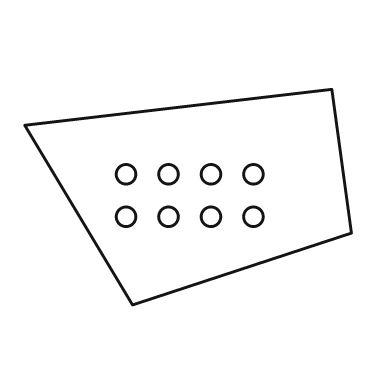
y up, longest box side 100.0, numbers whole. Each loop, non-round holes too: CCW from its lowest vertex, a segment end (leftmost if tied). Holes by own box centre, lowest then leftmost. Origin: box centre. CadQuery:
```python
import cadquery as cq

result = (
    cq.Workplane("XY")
    .moveTo(-17.0, -33.0)
    .lineTo(50.0, -11.0)
    .lineTo(44.0, 33.0)
    .lineTo(-50.0, 22.0)
    .close()
    .moveTo(-19.0, -6.0)
    .circle(3.0)
    .moveTo(-6.0, -6.0)
    .circle(3.0)
    .moveTo(7.0, -6.0)
    .circle(3.0)
    .moveTo(20.0, -6.0)
    .circle(3.0)
    .moveTo(-19.0, 7.0)
    .circle(3.0)
    .moveTo(-6.0, 7.0)
    .circle(3.0)
    .moveTo(7.0, 7.0)
    .circle(3.0)
    .moveTo(20.0, 7.0)
    .circle(3.0)
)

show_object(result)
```